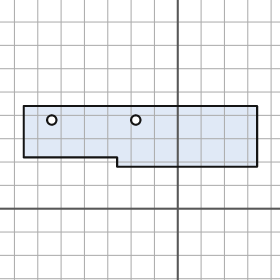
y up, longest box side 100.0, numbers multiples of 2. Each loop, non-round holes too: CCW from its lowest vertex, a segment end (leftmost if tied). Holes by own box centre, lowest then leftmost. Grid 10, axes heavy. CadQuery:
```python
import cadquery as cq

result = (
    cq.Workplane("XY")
    .moveTo(-26.0, 18.0)
    .lineTo(34.0, 18.0)
    .lineTo(34.0, 44.0)
    .lineTo(-66.0, 44.0)
    .lineTo(-66.0, 22.0)
    .lineTo(-26.0, 22.0)
    .close()
    .moveTo(-54.0, 38.0)
    .circle(2.0)
    .moveTo(-18.0, 38.0)
    .circle(2.0)
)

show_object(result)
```